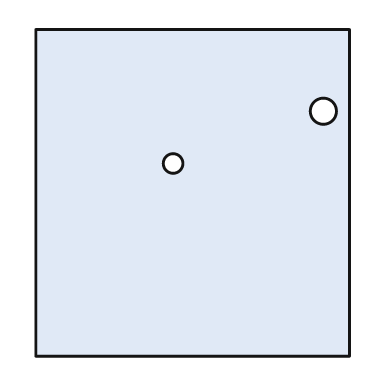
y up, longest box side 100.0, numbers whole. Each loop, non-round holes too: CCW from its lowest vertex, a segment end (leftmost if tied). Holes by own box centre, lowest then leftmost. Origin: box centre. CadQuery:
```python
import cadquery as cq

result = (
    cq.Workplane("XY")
    .moveTo(-48.0, -50.0)
    .lineTo(48.0, -50.0)
    .lineTo(48.0, 50.0)
    .lineTo(-48.0, 50.0)
    .close()
    .moveTo(-6.0, 9.0)
    .circle(3.0)
    .moveTo(40.0, 25.0)
    .circle(4.0)
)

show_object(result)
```